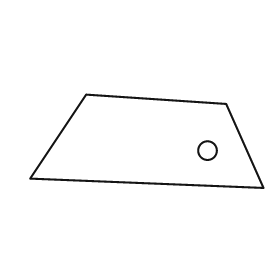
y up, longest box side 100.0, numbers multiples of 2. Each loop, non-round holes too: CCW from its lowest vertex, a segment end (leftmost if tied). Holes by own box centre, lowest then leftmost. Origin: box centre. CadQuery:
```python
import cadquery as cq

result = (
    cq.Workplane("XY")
    .moveTo(50.0, -20.0)
    .lineTo(34.0, 16.0)
    .lineTo(-26.0, 20.0)
    .lineTo(-50.0, -16.0)
    .close()
    .moveTo(26.0, -4.0)
    .circle(4.0)
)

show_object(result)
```